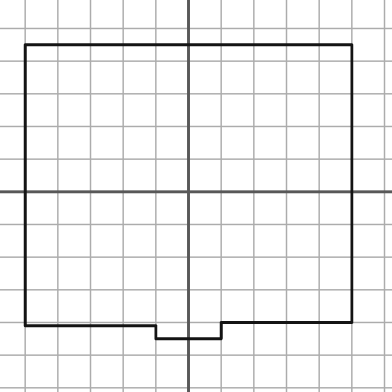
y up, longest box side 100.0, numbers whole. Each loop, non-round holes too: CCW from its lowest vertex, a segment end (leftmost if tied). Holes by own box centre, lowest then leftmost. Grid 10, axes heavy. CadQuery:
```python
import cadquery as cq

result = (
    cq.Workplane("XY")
    .moveTo(-10.0, -45.0)
    .lineTo(10.0, -45.0)
    .lineTo(10.0, -40.0)
    .lineTo(50.0, -40.0)
    .lineTo(50.0, 45.0)
    .lineTo(-50.0, 45.0)
    .lineTo(-50.0, -41.0)
    .lineTo(-10.0, -41.0)
    .close()
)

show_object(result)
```